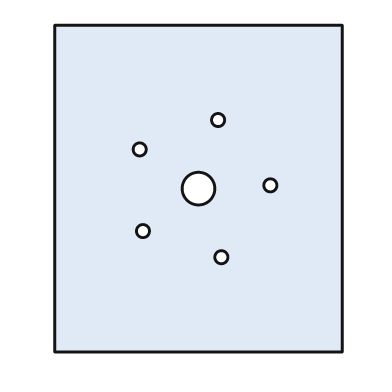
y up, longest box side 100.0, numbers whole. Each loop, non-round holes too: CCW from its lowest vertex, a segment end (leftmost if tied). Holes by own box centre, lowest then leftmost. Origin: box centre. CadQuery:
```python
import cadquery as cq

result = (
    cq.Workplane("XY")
    .moveTo(-44.0, -50.0)
    .lineTo(44.0, -50.0)
    .lineTo(44.0, 50.0)
    .lineTo(-44.0, 50.0)
    .close()
    .moveTo(7.0, -21.0)
    .circle(2.0)
    .moveTo(-17.0, -13.0)
    .circle(2.0)
    .moveTo(0.0, 0.0)
    .circle(5.0)
    .moveTo(22.0, 1.0)
    .circle(2.0)
    .moveTo(-18.0, 12.0)
    .circle(2.0)
    .moveTo(6.0, 21.0)
    .circle(2.0)
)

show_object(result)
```